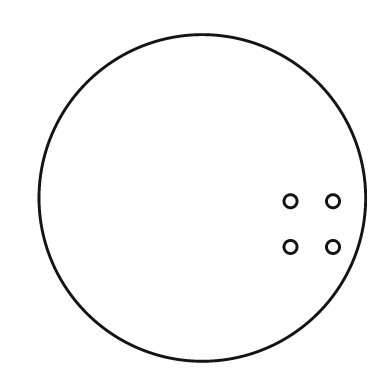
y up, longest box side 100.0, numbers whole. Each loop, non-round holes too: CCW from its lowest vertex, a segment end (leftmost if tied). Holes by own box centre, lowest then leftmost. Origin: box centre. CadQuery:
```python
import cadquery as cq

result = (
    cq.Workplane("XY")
    .moveTo(0.0, 0.0)
    .circle(50.0)
    .moveTo(27.0, -15.0)
    .circle(2.0)
    .moveTo(40.0, -15.0)
    .circle(2.0)
    .moveTo(27.0, -1.0)
    .circle(2.0)
    .moveTo(40.0, -1.0)
    .circle(2.0)
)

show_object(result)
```